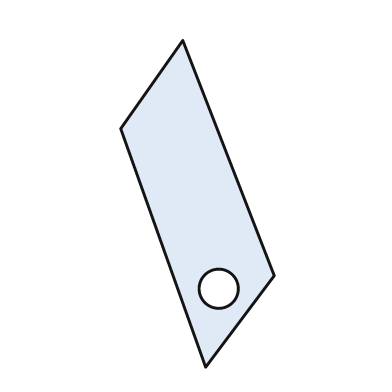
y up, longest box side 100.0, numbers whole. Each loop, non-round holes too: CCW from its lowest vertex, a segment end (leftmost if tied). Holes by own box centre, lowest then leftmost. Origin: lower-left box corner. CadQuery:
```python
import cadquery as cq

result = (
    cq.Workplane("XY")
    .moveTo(26.0, 0.0)
    .lineTo(47.0, 28.0)
    .lineTo(19.0, 100.0)
    .lineTo(0.0, 73.0)
    .close()
    .moveTo(30.0, 24.0)
    .circle(6.0)
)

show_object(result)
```